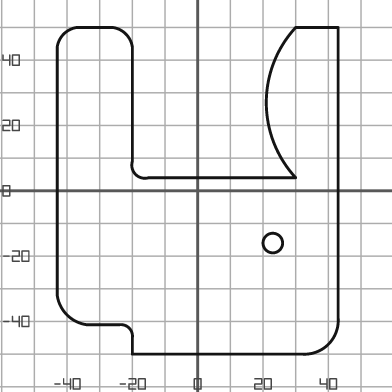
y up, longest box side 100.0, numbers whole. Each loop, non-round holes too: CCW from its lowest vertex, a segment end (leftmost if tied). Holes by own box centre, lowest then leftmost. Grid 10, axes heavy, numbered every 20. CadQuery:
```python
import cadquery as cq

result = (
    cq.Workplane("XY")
    .moveTo(-20.0, -50.0)
    .lineTo(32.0, -50.0)
    .threePointArc((40.0, -47.0), (43.0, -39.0))
    .lineTo(43.0, 50.0)
    .lineTo(30.0, 50.0)
    .threePointArc((21.0, 27.0), (30.0, 4.0))
    .lineTo(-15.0, 4.0)
    .threePointArc((-19.0, 5.0), (-20.0, 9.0))
    .lineTo(-20.0, 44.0)
    .threePointArc((-22.0, 48.0), (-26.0, 50.0))
    .lineTo(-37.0, 50.0)
    .threePointArc((-41.0, 48.0), (-43.0, 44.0))
    .lineTo(-43.0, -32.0)
    .threePointArc((-40.0, -38.0), (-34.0, -41.0))
    .lineTo(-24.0, -41.0)
    .threePointArc((-21.0, -42.0), (-20.0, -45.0))
    .close()
    .moveTo(23.0, -16.0)
    .circle(3.0)
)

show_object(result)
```